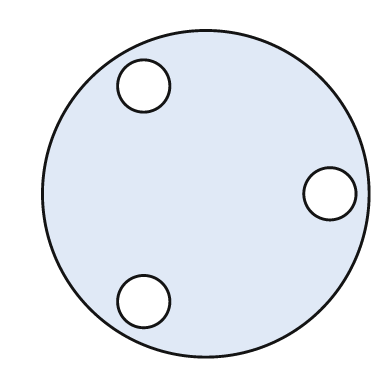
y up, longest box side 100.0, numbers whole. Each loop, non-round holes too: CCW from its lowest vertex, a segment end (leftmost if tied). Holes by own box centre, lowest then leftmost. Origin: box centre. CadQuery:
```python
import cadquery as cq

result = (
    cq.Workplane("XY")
    .moveTo(0.0, 0.0)
    .circle(50.0)
    .moveTo(-19.0, -33.0)
    .circle(8.0)
    .moveTo(38.0, 0.0)
    .circle(8.0)
    .moveTo(-19.0, 33.0)
    .circle(8.0)
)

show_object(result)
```